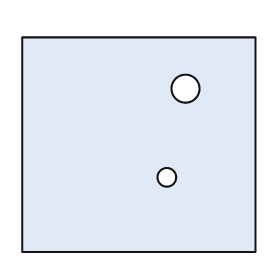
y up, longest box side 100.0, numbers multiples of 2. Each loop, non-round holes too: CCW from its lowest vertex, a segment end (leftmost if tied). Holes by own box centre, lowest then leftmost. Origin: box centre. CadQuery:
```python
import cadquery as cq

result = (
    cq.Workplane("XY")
    .moveTo(-50.0, -46.0)
    .lineTo(50.0, -46.0)
    .lineTo(50.0, 46.0)
    .lineTo(-50.0, 46.0)
    .close()
    .moveTo(12.0, -14.0)
    .circle(4.0)
    .moveTo(20.0, 24.0)
    .circle(6.0)
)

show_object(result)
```